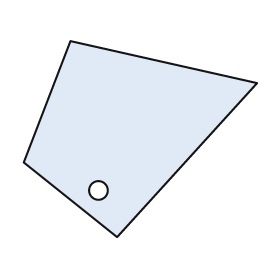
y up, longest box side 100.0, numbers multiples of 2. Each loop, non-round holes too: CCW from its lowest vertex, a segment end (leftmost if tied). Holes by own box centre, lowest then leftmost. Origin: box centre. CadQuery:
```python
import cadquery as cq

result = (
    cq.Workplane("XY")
    .moveTo(-10.0, -42.0)
    .lineTo(50.0, 24.0)
    .lineTo(-30.0, 42.0)
    .lineTo(-50.0, -10.0)
    .close()
    .moveTo(-18.0, -22.0)
    .circle(4.0)
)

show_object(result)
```